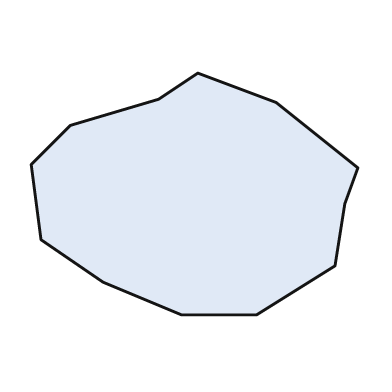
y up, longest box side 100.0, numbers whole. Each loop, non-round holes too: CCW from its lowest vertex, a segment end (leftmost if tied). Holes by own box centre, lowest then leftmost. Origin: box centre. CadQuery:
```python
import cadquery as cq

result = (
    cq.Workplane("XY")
    .moveTo(-4.0, -37.0)
    .lineTo(19.0, -37.0)
    .lineTo(43.0, -22.0)
    .lineTo(46.0, -3.0)
    .lineTo(50.0, 8.0)
    .lineTo(25.0, 28.0)
    .lineTo(1.0, 37.0)
    .lineTo(-11.0, 29.0)
    .lineTo(-38.0, 21.0)
    .lineTo(-50.0, 9.0)
    .lineTo(-47.0, -14.0)
    .lineTo(-28.0, -27.0)
    .close()
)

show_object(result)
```